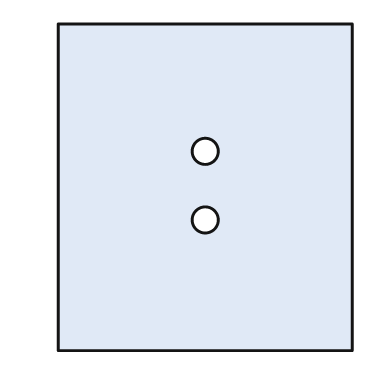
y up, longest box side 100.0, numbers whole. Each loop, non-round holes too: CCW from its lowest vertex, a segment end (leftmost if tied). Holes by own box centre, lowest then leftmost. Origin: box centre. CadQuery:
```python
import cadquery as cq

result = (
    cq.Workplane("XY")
    .moveTo(-45.0, -50.0)
    .lineTo(45.0, -50.0)
    .lineTo(45.0, 50.0)
    .lineTo(-45.0, 50.0)
    .close()
    .moveTo(0.0, -10.0)
    .circle(4.0)
    .moveTo(0.0, 11.0)
    .circle(4.0)
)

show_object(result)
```